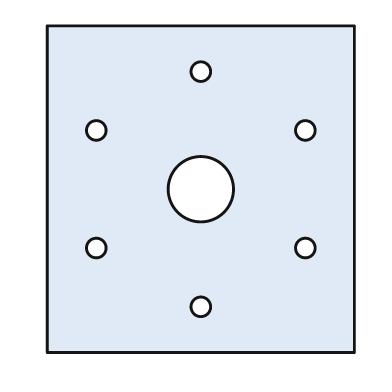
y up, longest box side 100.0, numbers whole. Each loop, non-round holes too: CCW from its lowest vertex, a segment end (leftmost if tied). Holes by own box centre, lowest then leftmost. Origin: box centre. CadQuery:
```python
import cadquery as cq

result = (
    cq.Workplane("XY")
    .moveTo(-47.0, -50.0)
    .lineTo(47.0, -50.0)
    .lineTo(47.0, 50.0)
    .lineTo(-47.0, 50.0)
    .close()
    .moveTo(0.0, -36.0)
    .circle(3.0)
    .moveTo(-32.0, -18.0)
    .circle(3.0)
    .moveTo(32.0, -18.0)
    .circle(3.0)
    .moveTo(0.0, 0.0)
    .circle(10.0)
    .moveTo(-32.0, 18.0)
    .circle(3.0)
    .moveTo(32.0, 18.0)
    .circle(3.0)
    .moveTo(0.0, 36.0)
    .circle(3.0)
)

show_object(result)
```